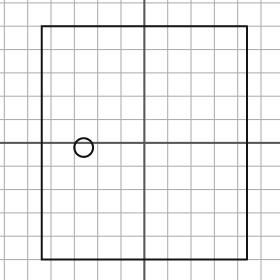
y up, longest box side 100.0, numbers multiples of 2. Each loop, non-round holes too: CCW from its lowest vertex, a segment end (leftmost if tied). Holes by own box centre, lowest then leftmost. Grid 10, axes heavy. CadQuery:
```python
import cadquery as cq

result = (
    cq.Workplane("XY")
    .moveTo(-44.0, -50.0)
    .lineTo(44.0, -50.0)
    .lineTo(44.0, 50.0)
    .lineTo(-44.0, 50.0)
    .close()
    .moveTo(-26.0, -2.0)
    .circle(4.0)
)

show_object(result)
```